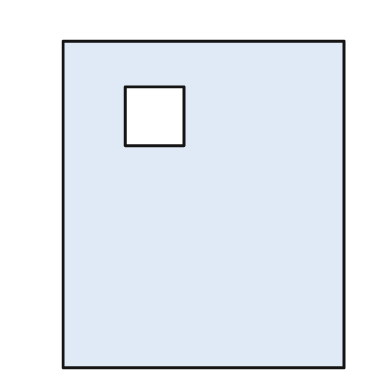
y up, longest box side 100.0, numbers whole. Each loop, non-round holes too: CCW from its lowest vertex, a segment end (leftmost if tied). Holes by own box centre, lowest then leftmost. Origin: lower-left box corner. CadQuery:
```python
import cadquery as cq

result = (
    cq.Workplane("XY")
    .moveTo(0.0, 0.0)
    .lineTo(86.0, 0.0)
    .lineTo(86.0, 100.0)
    .lineTo(0.0, 100.0)
    .close()
    .moveTo(19.0, 68.0)
    .lineTo(37.0, 68.0)
    .lineTo(37.0, 86.0)
    .lineTo(19.0, 86.0)
    .close()
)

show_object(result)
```